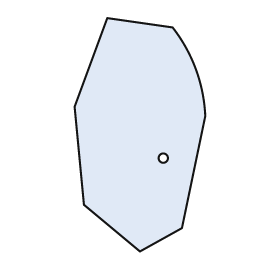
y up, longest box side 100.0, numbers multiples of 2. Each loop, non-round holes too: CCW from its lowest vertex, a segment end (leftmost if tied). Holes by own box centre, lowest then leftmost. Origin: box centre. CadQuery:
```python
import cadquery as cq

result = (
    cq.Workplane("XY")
    .moveTo(0.0, -50.0)
    .lineTo(18.0, -40.0)
    .lineTo(28.0, 8.0)
    .threePointArc((24.0, 28.0), (14.0, 46.0))
    .lineTo(-14.0, 50.0)
    .lineTo(-28.0, 12.0)
    .lineTo(-24.0, -30.0)
    .close()
    .moveTo(10.0, -10.0)
    .circle(2.0)
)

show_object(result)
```